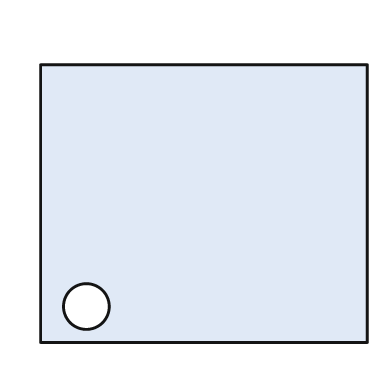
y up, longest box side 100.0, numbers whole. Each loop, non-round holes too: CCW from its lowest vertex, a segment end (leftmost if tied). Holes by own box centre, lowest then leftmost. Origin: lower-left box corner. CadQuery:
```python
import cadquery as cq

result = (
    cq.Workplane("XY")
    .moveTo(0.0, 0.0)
    .lineTo(100.0, 0.0)
    .lineTo(100.0, 85.0)
    .lineTo(0.0, 85.0)
    .close()
    .moveTo(14.0, 11.0)
    .circle(7.0)
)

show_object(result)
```